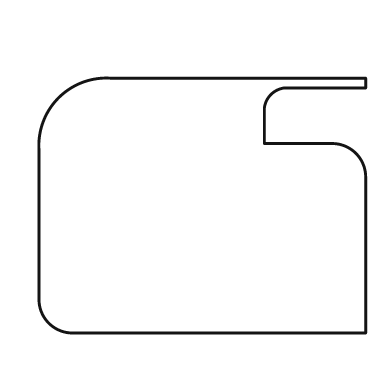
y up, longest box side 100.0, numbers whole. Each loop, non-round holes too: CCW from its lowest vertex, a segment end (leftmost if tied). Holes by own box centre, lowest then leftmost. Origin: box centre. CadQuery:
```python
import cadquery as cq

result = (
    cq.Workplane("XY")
    .moveTo(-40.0, -39.0)
    .lineTo(50.0, -39.0)
    .lineTo(50.0, 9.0)
    .threePointArc((47.0, 16.0), (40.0, 19.0))
    .lineTo(19.0, 19.0)
    .lineTo(19.0, 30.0)
    .threePointArc((21.0, 34.0), (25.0, 36.0))
    .lineTo(50.0, 36.0)
    .lineTo(50.0, 39.0)
    .lineTo(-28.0, 39.0)
    .threePointArc((-44.0, 33.0), (-50.0, 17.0))
    .lineTo(-50.0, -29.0)
    .threePointArc((-47.0, -36.0), (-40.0, -39.0))
    .close()
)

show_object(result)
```